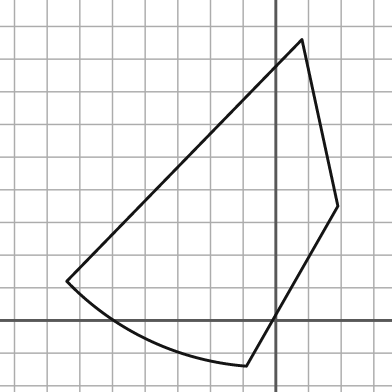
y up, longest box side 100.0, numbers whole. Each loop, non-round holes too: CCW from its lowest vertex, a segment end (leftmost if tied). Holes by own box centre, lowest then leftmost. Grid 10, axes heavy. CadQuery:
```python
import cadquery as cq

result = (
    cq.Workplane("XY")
    .moveTo(-9.0, -14.0)
    .lineTo(19.0, 35.0)
    .lineTo(8.0, 86.0)
    .lineTo(-64.0, 12.0)
    .threePointArc((-39.0, -6.0), (-9.0, -14.0))
    .close()
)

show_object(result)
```